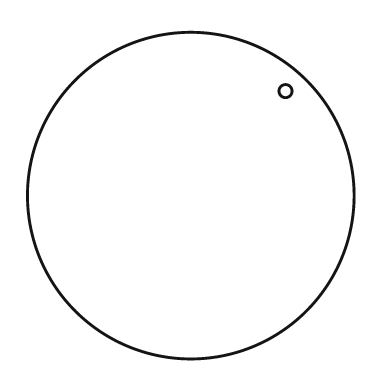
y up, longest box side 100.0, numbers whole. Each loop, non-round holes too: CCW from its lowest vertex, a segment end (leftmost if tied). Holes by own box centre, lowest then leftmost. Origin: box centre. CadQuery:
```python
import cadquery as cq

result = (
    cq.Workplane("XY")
    .moveTo(0.0, 0.0)
    .circle(50.0)
    .moveTo(29.0, 32.0)
    .circle(2.0)
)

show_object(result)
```